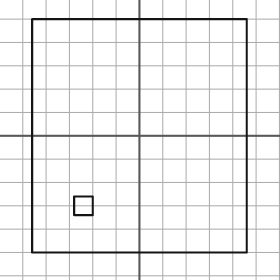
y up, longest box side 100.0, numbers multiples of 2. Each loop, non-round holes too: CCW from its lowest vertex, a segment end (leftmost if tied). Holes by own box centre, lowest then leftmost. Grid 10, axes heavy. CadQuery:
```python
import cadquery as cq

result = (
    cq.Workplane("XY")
    .moveTo(-46.0, -50.0)
    .lineTo(46.0, -50.0)
    .lineTo(46.0, 50.0)
    .lineTo(-46.0, 50.0)
    .close()
    .moveTo(-28.0, -34.0)
    .lineTo(-20.0, -34.0)
    .lineTo(-20.0, -26.0)
    .lineTo(-28.0, -26.0)
    .close()
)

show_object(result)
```